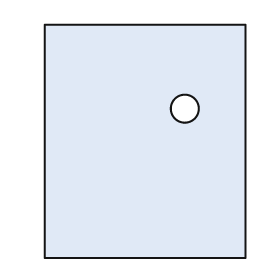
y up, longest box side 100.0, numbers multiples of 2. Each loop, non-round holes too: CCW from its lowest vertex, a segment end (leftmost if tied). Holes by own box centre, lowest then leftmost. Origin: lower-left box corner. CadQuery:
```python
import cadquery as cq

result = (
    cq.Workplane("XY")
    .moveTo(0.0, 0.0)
    .lineTo(86.0, 0.0)
    .lineTo(86.0, 100.0)
    .lineTo(0.0, 100.0)
    .close()
    .moveTo(60.0, 64.0)
    .circle(6.0)
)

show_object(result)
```